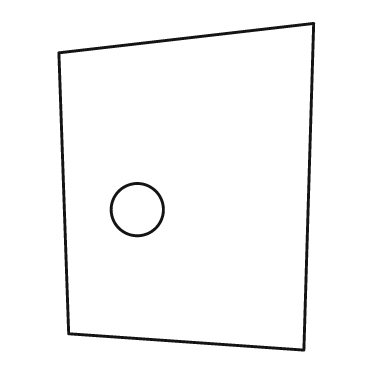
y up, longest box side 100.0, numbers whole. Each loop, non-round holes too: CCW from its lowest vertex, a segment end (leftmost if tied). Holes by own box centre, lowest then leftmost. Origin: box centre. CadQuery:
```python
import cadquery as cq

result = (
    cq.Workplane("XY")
    .moveTo(36.0, -50.0)
    .lineTo(39.0, 50.0)
    .lineTo(-39.0, 41.0)
    .lineTo(-36.0, -45.0)
    .close()
    .moveTo(-15.0, -7.0)
    .circle(8.0)
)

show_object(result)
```